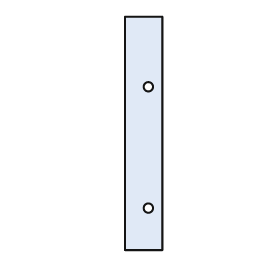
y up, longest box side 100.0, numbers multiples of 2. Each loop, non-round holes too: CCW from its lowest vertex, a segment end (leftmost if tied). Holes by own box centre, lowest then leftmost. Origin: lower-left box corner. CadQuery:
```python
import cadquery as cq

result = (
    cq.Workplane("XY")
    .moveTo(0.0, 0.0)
    .lineTo(16.0, 0.0)
    .lineTo(16.0, 100.0)
    .lineTo(0.0, 100.0)
    .close()
    .moveTo(10.0, 18.0)
    .circle(2.0)
    .moveTo(10.0, 70.0)
    .circle(2.0)
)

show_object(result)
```